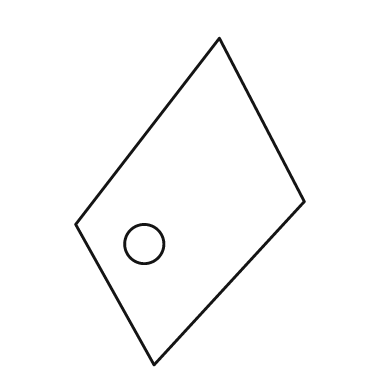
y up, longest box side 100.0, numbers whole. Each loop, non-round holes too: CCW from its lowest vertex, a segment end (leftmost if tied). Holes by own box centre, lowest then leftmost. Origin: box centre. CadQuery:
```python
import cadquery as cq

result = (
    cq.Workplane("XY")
    .moveTo(-11.0, -50.0)
    .lineTo(35.0, 0.0)
    .lineTo(9.0, 50.0)
    .lineTo(-35.0, -7.0)
    .close()
    .moveTo(-14.0, -13.0)
    .circle(6.0)
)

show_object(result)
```